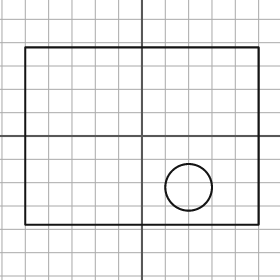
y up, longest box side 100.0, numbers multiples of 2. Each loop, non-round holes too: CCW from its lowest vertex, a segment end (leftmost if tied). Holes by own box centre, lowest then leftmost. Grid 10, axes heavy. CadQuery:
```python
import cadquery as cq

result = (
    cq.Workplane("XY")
    .moveTo(-50.0, -38.0)
    .lineTo(50.0, -38.0)
    .lineTo(50.0, 38.0)
    .lineTo(-50.0, 38.0)
    .close()
    .moveTo(20.0, -22.0)
    .circle(10.0)
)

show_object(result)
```